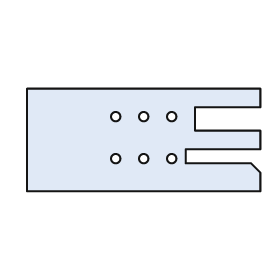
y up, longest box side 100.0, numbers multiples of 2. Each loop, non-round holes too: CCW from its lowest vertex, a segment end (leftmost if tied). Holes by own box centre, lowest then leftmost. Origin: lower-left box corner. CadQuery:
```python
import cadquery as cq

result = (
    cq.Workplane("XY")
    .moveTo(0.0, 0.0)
    .lineTo(100.0, 0.0)
    .lineTo(100.0, 8.0)
    .lineTo(96.0, 12.0)
    .lineTo(68.0, 12.0)
    .lineTo(68.0, 18.0)
    .lineTo(100.0, 18.0)
    .lineTo(100.0, 26.0)
    .lineTo(72.0, 26.0)
    .lineTo(72.0, 36.0)
    .lineTo(100.0, 36.0)
    .lineTo(100.0, 44.0)
    .lineTo(0.0, 44.0)
    .close()
    .moveTo(38.0, 14.0)
    .circle(2.0)
    .moveTo(50.0, 14.0)
    .circle(2.0)
    .moveTo(62.0, 14.0)
    .circle(2.0)
    .moveTo(38.0, 32.0)
    .circle(2.0)
    .moveTo(50.0, 32.0)
    .circle(2.0)
    .moveTo(62.0, 32.0)
    .circle(2.0)
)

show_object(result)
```